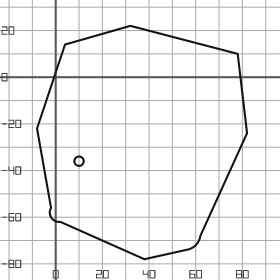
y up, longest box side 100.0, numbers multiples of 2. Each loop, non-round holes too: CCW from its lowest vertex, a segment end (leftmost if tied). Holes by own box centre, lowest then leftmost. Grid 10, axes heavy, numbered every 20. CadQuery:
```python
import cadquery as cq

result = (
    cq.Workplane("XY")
    .moveTo(38.0, -78.0)
    .lineTo(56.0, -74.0)
    .threePointArc((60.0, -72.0), (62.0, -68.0))
    .lineTo(82.0, -24.0)
    .lineTo(78.0, 10.0)
    .lineTo(32.0, 22.0)
    .lineTo(4.0, 14.0)
    .lineTo(-8.0, -22.0)
    .lineTo(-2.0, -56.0)
    .threePointArc((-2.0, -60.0), (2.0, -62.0))
    .close()
    .moveTo(10.0, -36.0)
    .circle(2.0)
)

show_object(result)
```